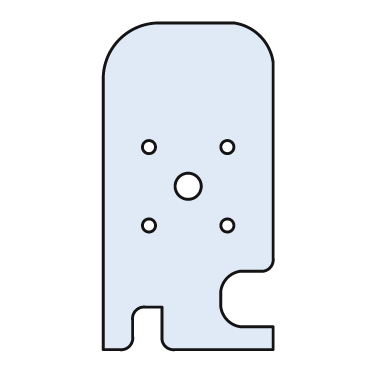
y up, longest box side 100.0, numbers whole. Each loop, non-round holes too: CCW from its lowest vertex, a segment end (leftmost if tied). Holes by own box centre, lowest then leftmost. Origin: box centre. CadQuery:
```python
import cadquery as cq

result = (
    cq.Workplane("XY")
    .moveTo(-26.0, -50.0)
    .lineTo(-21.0, -50.0)
    .threePointArc((-18.0, -49.0), (-17.0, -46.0))
    .lineTo(-17.0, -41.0)
    .threePointArc((-16.0, -38.0), (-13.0, -37.0))
    .lineTo(-8.0, -37.0)
    .lineTo(-8.0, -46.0)
    .threePointArc((-7.0, -49.0), (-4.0, -50.0))
    .lineTo(26.0, -50.0)
    .lineTo(26.0, -43.0)
    .lineTo(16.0, -43.0)
    .threePointArc((12.0, -41.0), (10.0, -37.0))
    .lineTo(10.0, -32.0)
    .threePointArc((12.0, -28.0), (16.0, -26.0))
    .lineTo(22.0, -26.0)
    .threePointArc((25.0, -25.0), (26.0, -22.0))
    .lineTo(26.0, 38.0)
    .threePointArc((22.0, 46.0), (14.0, 50.0))
    .lineTo(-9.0, 50.0)
    .threePointArc((-21.0, 45.0), (-26.0, 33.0))
    .close()
    .moveTo(-12.0, -12.0)
    .circle(2.0)
    .moveTo(12.0, -12.0)
    .circle(2.0)
    .moveTo(0.0, 0.0)
    .circle(4.0)
    .moveTo(-12.0, 12.0)
    .circle(2.0)
    .moveTo(12.0, 12.0)
    .circle(2.0)
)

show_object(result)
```